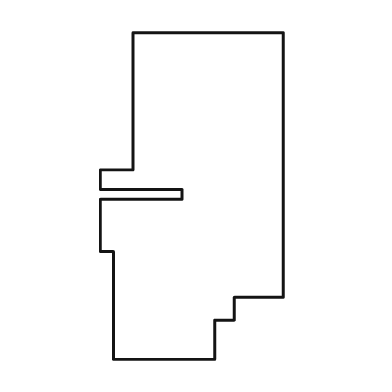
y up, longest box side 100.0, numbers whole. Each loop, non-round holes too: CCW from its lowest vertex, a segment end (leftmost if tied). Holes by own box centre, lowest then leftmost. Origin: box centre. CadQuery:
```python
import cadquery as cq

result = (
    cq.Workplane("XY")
    .moveTo(-24.0, -50.0)
    .lineTo(7.0, -50.0)
    .lineTo(7.0, -38.0)
    .lineTo(13.0, -38.0)
    .lineTo(13.0, -31.0)
    .lineTo(28.0, -31.0)
    .lineTo(28.0, 50.0)
    .lineTo(-18.0, 50.0)
    .lineTo(-18.0, 8.0)
    .lineTo(-28.0, 8.0)
    .lineTo(-28.0, 2.0)
    .lineTo(-3.0, 2.0)
    .lineTo(-3.0, -1.0)
    .lineTo(-28.0, -1.0)
    .lineTo(-28.0, -17.0)
    .lineTo(-24.0, -17.0)
    .close()
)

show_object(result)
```